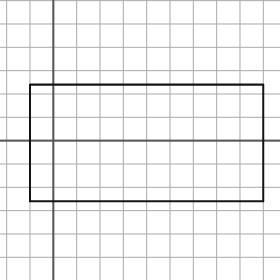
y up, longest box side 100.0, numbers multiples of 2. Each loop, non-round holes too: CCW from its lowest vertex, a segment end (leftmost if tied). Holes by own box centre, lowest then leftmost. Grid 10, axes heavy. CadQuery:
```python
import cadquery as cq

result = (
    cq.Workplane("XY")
    .moveTo(-10.0, -26.0)
    .lineTo(90.0, -26.0)
    .lineTo(90.0, 24.0)
    .lineTo(-10.0, 24.0)
    .close()
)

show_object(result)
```